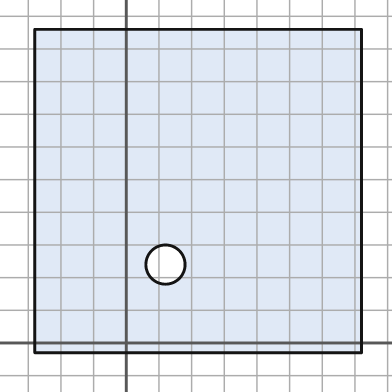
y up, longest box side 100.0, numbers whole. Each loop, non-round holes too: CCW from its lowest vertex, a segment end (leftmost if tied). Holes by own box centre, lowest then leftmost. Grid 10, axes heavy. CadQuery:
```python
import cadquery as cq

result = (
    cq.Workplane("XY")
    .moveTo(-28.0, -3.0)
    .lineTo(72.0, -3.0)
    .lineTo(72.0, 96.0)
    .lineTo(-28.0, 96.0)
    .close()
    .moveTo(12.0, 24.0)
    .circle(6.0)
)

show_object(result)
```